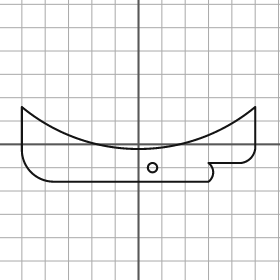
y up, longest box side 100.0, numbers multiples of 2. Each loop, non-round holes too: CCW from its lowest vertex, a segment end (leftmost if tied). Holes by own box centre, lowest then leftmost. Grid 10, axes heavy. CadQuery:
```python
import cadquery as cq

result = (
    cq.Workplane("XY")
    .moveTo(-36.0, -16.0)
    .lineTo(30.0, -16.0)
    .threePointArc((32.0, -12.0), (30.0, -8.0))
    .lineTo(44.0, -8.0)
    .threePointArc((48.0, -6.0), (50.0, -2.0))
    .lineTo(50.0, 16.0)
    .threePointArc((0.0, -2.0), (-50.0, 16.0))
    .lineTo(-50.0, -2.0)
    .threePointArc((-46.0, -12.0), (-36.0, -16.0))
    .close()
    .moveTo(6.0, -10.0)
    .circle(2.0)
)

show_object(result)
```